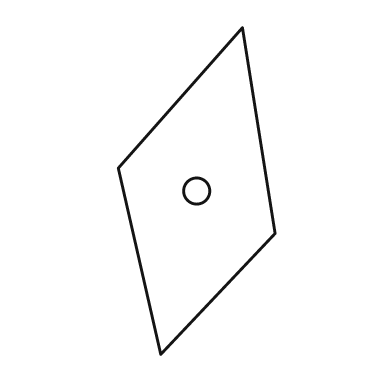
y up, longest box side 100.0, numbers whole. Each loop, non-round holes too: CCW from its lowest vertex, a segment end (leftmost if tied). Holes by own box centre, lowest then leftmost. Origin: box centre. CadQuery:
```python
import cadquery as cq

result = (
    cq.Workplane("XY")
    .moveTo(-11.0, -50.0)
    .lineTo(24.0, -13.0)
    .lineTo(14.0, 50.0)
    .lineTo(-24.0, 7.0)
    .close()
    .moveTo(0.0, 0.0)
    .circle(4.0)
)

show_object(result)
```